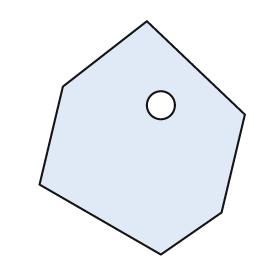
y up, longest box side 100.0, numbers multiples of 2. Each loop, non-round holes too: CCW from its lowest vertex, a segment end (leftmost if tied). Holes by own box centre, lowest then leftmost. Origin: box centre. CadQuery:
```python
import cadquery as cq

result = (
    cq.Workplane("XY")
    .moveTo(8.0, -50.0)
    .lineTo(34.0, -32.0)
    .lineTo(44.0, 10.0)
    .lineTo(2.0, 50.0)
    .lineTo(-34.0, 22.0)
    .lineTo(-44.0, -20.0)
    .close()
    .moveTo(8.0, 14.0)
    .circle(6.0)
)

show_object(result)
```